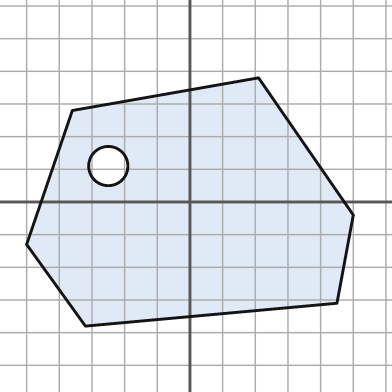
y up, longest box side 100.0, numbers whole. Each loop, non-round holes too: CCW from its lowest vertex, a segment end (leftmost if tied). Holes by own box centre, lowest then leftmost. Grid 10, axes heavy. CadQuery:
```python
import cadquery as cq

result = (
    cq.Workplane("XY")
    .moveTo(-32.0, -38.0)
    .lineTo(45.0, -31.0)
    .lineTo(50.0, -4.0)
    .lineTo(21.0, 38.0)
    .lineTo(-36.0, 28.0)
    .lineTo(-50.0, -13.0)
    .close()
    .moveTo(-25.0, 11.0)
    .circle(6.0)
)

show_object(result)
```